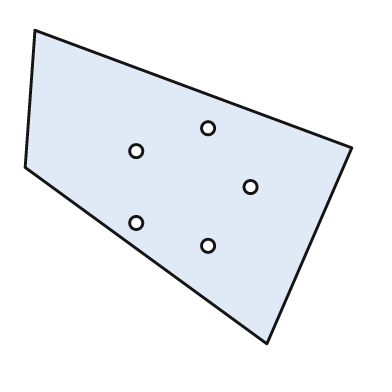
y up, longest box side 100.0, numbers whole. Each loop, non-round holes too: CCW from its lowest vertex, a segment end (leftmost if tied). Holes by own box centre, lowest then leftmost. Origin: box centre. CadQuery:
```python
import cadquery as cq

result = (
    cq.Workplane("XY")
    .moveTo(24.0, -48.0)
    .lineTo(50.0, 12.0)
    .lineTo(-47.0, 48.0)
    .lineTo(-50.0, 6.0)
    .close()
    .moveTo(6.0, -18.0)
    .circle(2.0)
    .moveTo(-16.0, -11.0)
    .circle(2.0)
    .moveTo(19.0, 0.0)
    .circle(2.0)
    .moveTo(-16.0, 11.0)
    .circle(2.0)
    .moveTo(6.0, 18.0)
    .circle(2.0)
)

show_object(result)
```